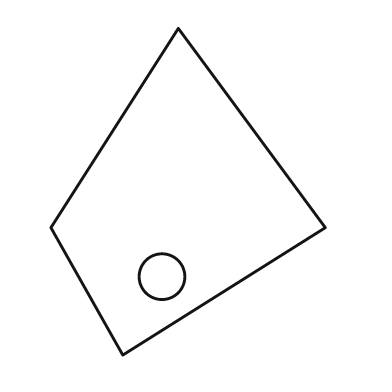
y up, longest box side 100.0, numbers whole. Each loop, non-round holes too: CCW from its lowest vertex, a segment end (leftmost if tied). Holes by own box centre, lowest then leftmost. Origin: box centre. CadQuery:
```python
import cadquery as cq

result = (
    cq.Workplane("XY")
    .moveTo(-20.0, -50.0)
    .lineTo(42.0, -11.0)
    .lineTo(-3.0, 50.0)
    .lineTo(-42.0, -11.0)
    .close()
    .moveTo(-8.0, -26.0)
    .circle(7.0)
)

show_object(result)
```